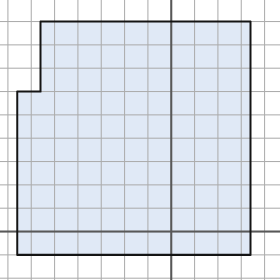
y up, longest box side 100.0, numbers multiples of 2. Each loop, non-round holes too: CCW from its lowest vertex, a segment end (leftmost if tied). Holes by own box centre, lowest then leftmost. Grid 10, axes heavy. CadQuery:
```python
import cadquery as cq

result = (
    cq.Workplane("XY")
    .moveTo(-66.0, -10.0)
    .lineTo(34.0, -10.0)
    .lineTo(34.0, 90.0)
    .lineTo(-56.0, 90.0)
    .lineTo(-56.0, 60.0)
    .lineTo(-66.0, 60.0)
    .close()
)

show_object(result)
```